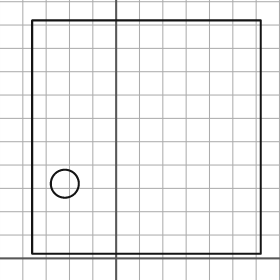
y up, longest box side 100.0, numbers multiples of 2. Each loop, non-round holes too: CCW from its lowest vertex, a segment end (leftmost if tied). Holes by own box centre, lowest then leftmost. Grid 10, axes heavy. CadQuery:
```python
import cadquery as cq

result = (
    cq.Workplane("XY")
    .moveTo(-36.0, 2.0)
    .lineTo(62.0, 2.0)
    .lineTo(62.0, 102.0)
    .lineTo(-36.0, 102.0)
    .close()
    .moveTo(-22.0, 32.0)
    .circle(6.0)
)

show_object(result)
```